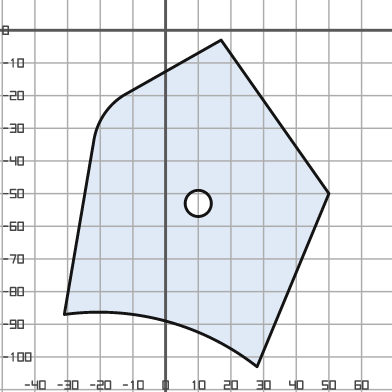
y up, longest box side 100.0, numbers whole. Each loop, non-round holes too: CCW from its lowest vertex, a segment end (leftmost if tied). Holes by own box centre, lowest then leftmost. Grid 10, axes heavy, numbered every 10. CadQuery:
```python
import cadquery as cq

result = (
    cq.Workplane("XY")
    .moveTo(28.0, -103.0)
    .lineTo(50.0, -50.0)
    .lineTo(17.0, -3.0)
    .lineTo(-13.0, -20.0)
    .threePointArc((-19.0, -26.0), (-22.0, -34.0))
    .lineTo(-31.0, -87.0)
    .threePointArc((0.0, -89.0), (28.0, -103.0))
    .close()
    .moveTo(10.0, -53.0)
    .circle(4.0)
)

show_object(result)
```